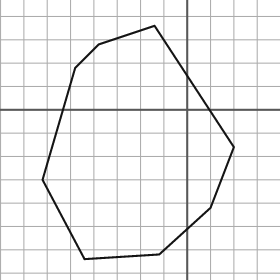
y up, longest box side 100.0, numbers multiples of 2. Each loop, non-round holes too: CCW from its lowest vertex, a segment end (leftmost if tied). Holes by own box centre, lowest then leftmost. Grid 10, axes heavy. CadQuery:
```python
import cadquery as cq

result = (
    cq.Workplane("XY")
    .moveTo(-44.0, -64.0)
    .lineTo(-12.0, -62.0)
    .lineTo(10.0, -42.0)
    .lineTo(20.0, -16.0)
    .lineTo(-14.0, 36.0)
    .lineTo(-38.0, 28.0)
    .lineTo(-48.0, 18.0)
    .lineTo(-62.0, -30.0)
    .close()
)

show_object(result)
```